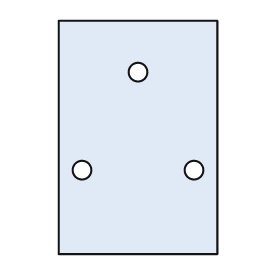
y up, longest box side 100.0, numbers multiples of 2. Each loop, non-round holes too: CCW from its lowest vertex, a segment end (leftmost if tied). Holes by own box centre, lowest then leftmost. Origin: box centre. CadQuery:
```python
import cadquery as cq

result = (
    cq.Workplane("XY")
    .moveTo(-34.0, -50.0)
    .lineTo(34.0, -50.0)
    .lineTo(34.0, 50.0)
    .lineTo(-34.0, 50.0)
    .close()
    .moveTo(-24.0, -14.0)
    .circle(4.0)
    .moveTo(24.0, -14.0)
    .circle(4.0)
    .moveTo(0.0, 28.0)
    .circle(4.0)
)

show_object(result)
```